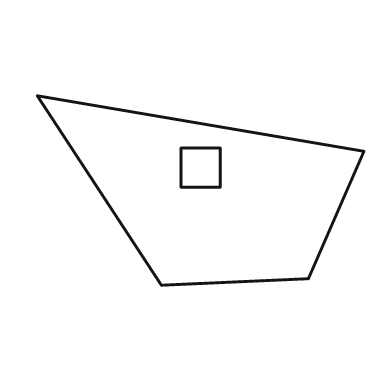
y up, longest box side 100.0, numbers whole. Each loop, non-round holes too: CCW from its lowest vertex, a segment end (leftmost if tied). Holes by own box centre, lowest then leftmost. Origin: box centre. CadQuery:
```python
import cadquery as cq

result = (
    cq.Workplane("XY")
    .moveTo(-12.0, -29.0)
    .lineTo(33.0, -27.0)
    .lineTo(50.0, 12.0)
    .lineTo(-50.0, 29.0)
    .close()
    .moveTo(-6.0, 1.0)
    .lineTo(6.0, 1.0)
    .lineTo(6.0, 13.0)
    .lineTo(-6.0, 13.0)
    .close()
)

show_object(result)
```